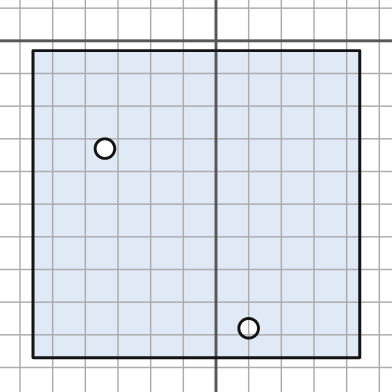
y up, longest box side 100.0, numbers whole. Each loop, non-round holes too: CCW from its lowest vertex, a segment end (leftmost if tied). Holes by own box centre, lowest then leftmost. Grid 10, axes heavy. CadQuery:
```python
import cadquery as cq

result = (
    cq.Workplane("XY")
    .moveTo(-56.0, -97.0)
    .lineTo(44.0, -97.0)
    .lineTo(44.0, -3.0)
    .lineTo(-56.0, -3.0)
    .close()
    .moveTo(10.0, -88.0)
    .circle(3.0)
    .moveTo(-34.0, -33.0)
    .circle(3.0)
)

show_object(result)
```